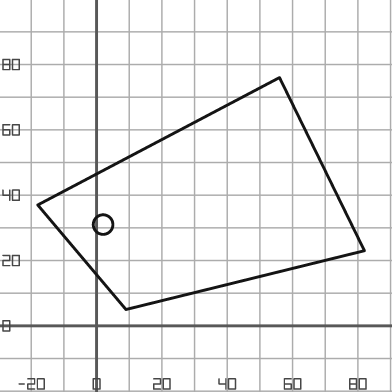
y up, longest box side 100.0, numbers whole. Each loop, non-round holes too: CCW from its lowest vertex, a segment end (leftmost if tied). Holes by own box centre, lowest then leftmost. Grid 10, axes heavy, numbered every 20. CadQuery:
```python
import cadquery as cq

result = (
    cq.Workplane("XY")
    .moveTo(9.0, 5.0)
    .lineTo(82.0, 23.0)
    .lineTo(56.0, 76.0)
    .lineTo(-18.0, 37.0)
    .close()
    .moveTo(2.0, 31.0)
    .circle(3.0)
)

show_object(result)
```